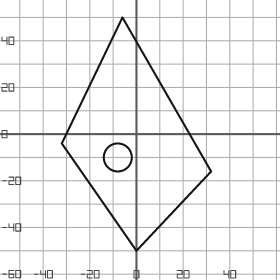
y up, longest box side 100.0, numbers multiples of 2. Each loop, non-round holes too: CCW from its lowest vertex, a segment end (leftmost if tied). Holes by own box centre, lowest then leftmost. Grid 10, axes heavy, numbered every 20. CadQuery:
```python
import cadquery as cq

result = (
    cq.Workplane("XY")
    .moveTo(0.0, -50.0)
    .lineTo(32.0, -16.0)
    .lineTo(-6.0, 50.0)
    .lineTo(-32.0, -4.0)
    .close()
    .moveTo(-8.0, -10.0)
    .circle(6.0)
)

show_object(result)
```